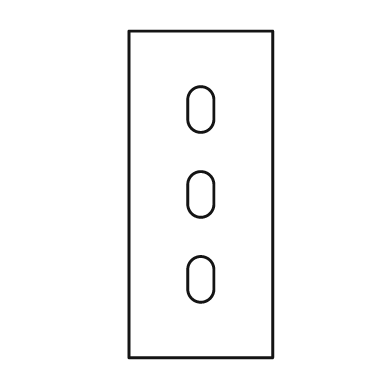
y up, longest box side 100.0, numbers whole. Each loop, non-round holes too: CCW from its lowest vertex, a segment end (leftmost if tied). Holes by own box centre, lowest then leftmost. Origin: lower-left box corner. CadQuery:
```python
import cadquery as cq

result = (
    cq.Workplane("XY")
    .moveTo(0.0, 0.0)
    .lineTo(44.0, 0.0)
    .lineTo(44.0, 100.0)
    .lineTo(0.0, 100.0)
    .close()
    .moveTo(18.0, 21.0)
    .threePointArc((22.0, 17.0), (26.0, 21.0))
    .lineTo(26.0, 27.0)
    .threePointArc((22.0, 31.0), (18.0, 27.0))
    .close()
    .moveTo(18.0, 47.0)
    .threePointArc((22.0, 43.0), (26.0, 47.0))
    .lineTo(26.0, 53.0)
    .threePointArc((22.0, 57.0), (18.0, 53.0))
    .close()
    .moveTo(18.0, 73.0)
    .threePointArc((22.0, 69.0), (26.0, 73.0))
    .lineTo(26.0, 79.0)
    .threePointArc((22.0, 83.0), (18.0, 79.0))
    .close()
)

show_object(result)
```